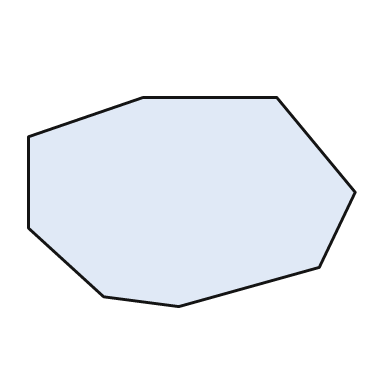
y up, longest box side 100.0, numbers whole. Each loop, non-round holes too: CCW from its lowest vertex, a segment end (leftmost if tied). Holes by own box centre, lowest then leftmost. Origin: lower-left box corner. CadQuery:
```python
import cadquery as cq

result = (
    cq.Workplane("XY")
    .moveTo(46.0, 0.0)
    .lineTo(89.0, 12.0)
    .lineTo(100.0, 35.0)
    .lineTo(76.0, 64.0)
    .lineTo(35.0, 64.0)
    .lineTo(0.0, 52.0)
    .lineTo(0.0, 24.0)
    .lineTo(23.0, 3.0)
    .close()
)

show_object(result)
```